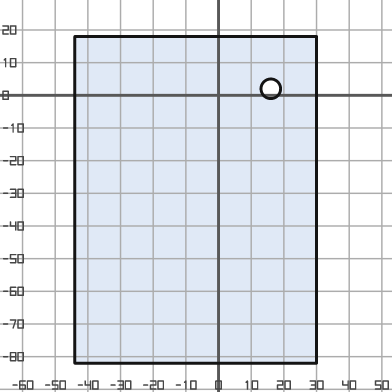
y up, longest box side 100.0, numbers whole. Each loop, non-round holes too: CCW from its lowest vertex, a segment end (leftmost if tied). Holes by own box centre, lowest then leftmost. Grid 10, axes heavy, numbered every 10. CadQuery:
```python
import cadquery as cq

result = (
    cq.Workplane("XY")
    .moveTo(-44.0, -82.0)
    .lineTo(30.0, -82.0)
    .lineTo(30.0, 18.0)
    .lineTo(-44.0, 18.0)
    .close()
    .moveTo(16.0, 2.0)
    .circle(3.0)
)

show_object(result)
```